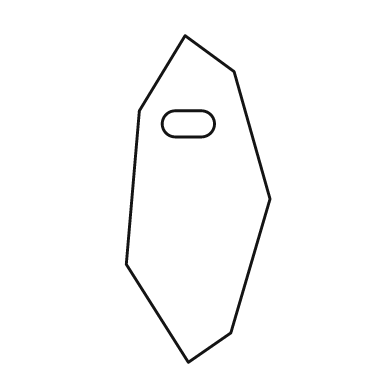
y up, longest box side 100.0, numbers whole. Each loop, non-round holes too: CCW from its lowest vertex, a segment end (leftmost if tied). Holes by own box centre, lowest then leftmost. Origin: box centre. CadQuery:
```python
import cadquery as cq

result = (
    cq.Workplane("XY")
    .moveTo(-3.0, -50.0)
    .lineTo(10.0, -41.0)
    .lineTo(22.0, 0.0)
    .lineTo(11.0, 39.0)
    .lineTo(-4.0, 50.0)
    .lineTo(-18.0, 27.0)
    .lineTo(-22.0, -20.0)
    .close()
    .moveTo(-7.0, 19.0)
    .lineTo(1.0, 19.0)
    .threePointArc((5.0, 23.0), (1.0, 27.0))
    .lineTo(-7.0, 27.0)
    .threePointArc((-11.0, 23.0), (-7.0, 19.0))
    .close()
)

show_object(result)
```